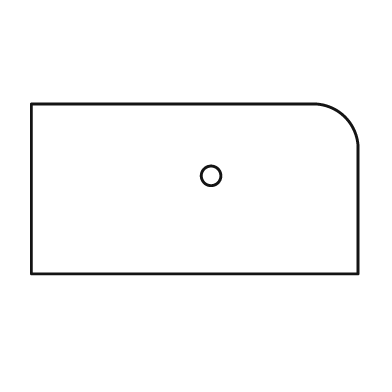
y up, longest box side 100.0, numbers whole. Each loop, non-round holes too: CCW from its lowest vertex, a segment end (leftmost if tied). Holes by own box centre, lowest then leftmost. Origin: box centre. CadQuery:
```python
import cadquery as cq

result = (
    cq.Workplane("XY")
    .moveTo(-50.0, -26.0)
    .lineTo(50.0, -26.0)
    .lineTo(50.0, 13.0)
    .threePointArc((46.0, 22.0), (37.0, 26.0))
    .lineTo(-50.0, 26.0)
    .close()
    .moveTo(5.0, 4.0)
    .circle(3.0)
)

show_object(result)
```